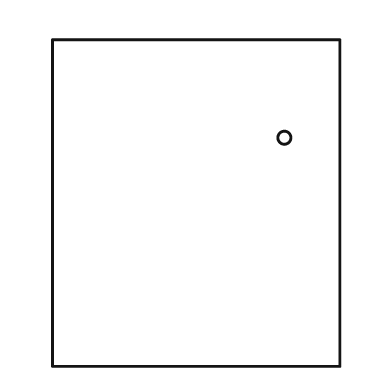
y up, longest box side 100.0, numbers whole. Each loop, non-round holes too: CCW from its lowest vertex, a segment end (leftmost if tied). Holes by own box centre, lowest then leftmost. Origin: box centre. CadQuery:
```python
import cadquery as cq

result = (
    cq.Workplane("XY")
    .moveTo(-44.0, -50.0)
    .lineTo(44.0, -50.0)
    .lineTo(44.0, 50.0)
    .lineTo(-44.0, 50.0)
    .close()
    .moveTo(27.0, 20.0)
    .circle(2.0)
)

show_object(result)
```